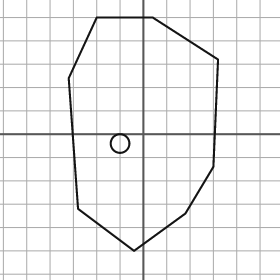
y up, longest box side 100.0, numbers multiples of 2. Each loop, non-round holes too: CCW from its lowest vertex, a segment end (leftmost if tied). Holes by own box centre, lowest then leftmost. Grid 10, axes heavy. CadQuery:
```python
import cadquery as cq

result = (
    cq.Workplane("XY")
    .moveTo(-4.0, -50.0)
    .lineTo(18.0, -34.0)
    .lineTo(30.0, -14.0)
    .lineTo(32.0, 32.0)
    .lineTo(4.0, 50.0)
    .lineTo(-20.0, 50.0)
    .lineTo(-32.0, 24.0)
    .lineTo(-28.0, -32.0)
    .close()
    .moveTo(-10.0, -4.0)
    .circle(4.0)
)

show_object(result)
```